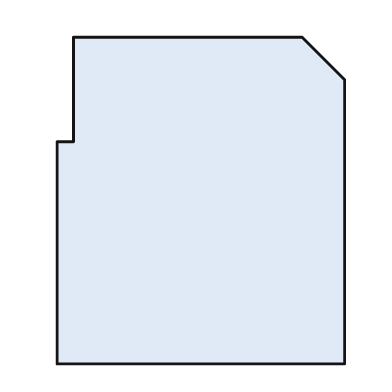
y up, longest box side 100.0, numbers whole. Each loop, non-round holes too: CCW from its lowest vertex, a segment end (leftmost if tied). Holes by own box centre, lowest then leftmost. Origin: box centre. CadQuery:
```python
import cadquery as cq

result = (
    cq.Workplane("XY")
    .moveTo(-44.0, -50.0)
    .lineTo(44.0, -50.0)
    .lineTo(44.0, 37.0)
    .lineTo(31.0, 50.0)
    .lineTo(-39.0, 50.0)
    .lineTo(-39.0, 18.0)
    .lineTo(-44.0, 18.0)
    .close()
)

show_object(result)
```